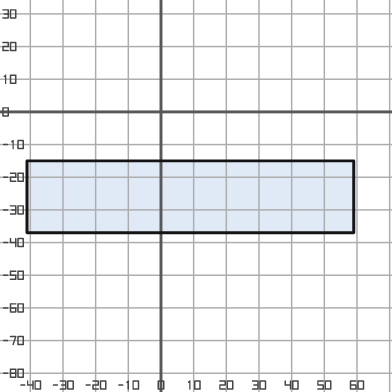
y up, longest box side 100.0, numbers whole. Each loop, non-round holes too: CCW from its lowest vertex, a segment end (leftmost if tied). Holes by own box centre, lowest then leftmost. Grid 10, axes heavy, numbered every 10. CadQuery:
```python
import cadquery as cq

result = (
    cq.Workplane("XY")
    .moveTo(-41.0, -37.0)
    .lineTo(59.0, -37.0)
    .lineTo(59.0, -15.0)
    .lineTo(-41.0, -15.0)
    .close()
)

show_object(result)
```